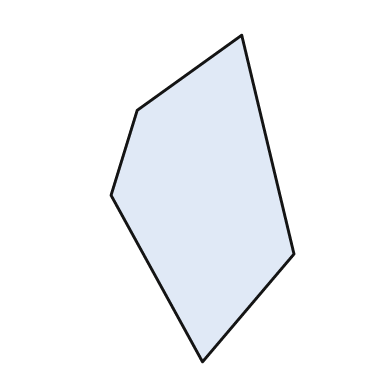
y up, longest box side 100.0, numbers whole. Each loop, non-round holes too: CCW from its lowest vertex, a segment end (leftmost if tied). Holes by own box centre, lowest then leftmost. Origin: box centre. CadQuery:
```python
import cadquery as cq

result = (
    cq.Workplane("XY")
    .moveTo(0.0, -50.0)
    .lineTo(28.0, -17.0)
    .lineTo(12.0, 50.0)
    .lineTo(-20.0, 27.0)
    .lineTo(-28.0, 1.0)
    .close()
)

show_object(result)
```